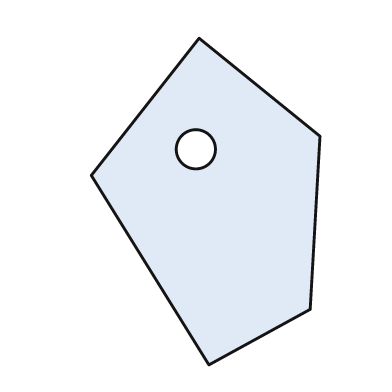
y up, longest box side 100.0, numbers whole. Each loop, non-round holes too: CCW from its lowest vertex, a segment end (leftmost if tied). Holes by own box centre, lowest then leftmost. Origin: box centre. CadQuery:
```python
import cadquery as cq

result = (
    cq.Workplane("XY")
    .moveTo(1.0, -50.0)
    .lineTo(32.0, -33.0)
    .lineTo(35.0, 20.0)
    .lineTo(-2.0, 50.0)
    .lineTo(-35.0, 8.0)
    .close()
    .moveTo(-3.0, 16.0)
    .circle(6.0)
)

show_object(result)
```